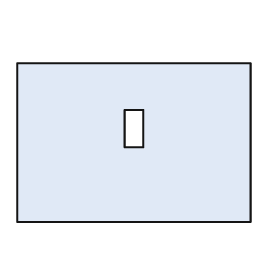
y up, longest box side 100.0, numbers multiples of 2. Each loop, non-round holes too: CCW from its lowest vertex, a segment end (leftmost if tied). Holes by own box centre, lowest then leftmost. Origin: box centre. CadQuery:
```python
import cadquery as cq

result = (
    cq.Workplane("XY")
    .moveTo(-50.0, -34.0)
    .lineTo(50.0, -34.0)
    .lineTo(50.0, 34.0)
    .lineTo(-50.0, 34.0)
    .close()
    .moveTo(-4.0, -2.0)
    .lineTo(4.0, -2.0)
    .lineTo(4.0, 14.0)
    .lineTo(-4.0, 14.0)
    .close()
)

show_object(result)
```